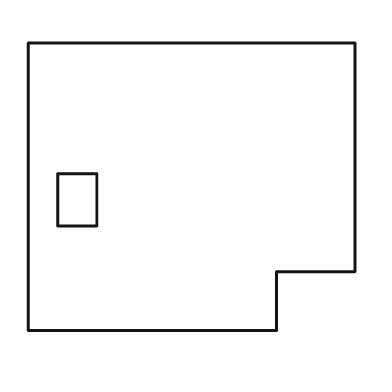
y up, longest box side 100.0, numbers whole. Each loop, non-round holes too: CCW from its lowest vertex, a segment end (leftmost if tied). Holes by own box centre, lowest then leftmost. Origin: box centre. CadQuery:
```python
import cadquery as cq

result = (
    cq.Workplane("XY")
    .moveTo(-50.0, -44.0)
    .lineTo(26.0, -44.0)
    .lineTo(26.0, -26.0)
    .lineTo(50.0, -26.0)
    .lineTo(50.0, 44.0)
    .lineTo(-50.0, 44.0)
    .close()
    .moveTo(-41.0, -12.0)
    .lineTo(-29.0, -12.0)
    .lineTo(-29.0, 4.0)
    .lineTo(-41.0, 4.0)
    .close()
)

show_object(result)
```